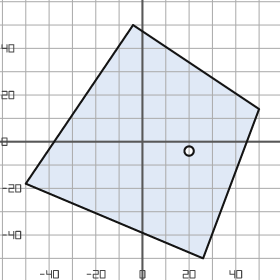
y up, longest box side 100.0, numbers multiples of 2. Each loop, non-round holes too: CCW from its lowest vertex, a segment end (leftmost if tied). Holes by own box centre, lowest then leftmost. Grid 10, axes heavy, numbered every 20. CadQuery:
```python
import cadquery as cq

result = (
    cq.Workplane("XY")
    .moveTo(26.0, -50.0)
    .lineTo(50.0, 14.0)
    .lineTo(-4.0, 50.0)
    .lineTo(-50.0, -18.0)
    .close()
    .moveTo(20.0, -4.0)
    .circle(2.0)
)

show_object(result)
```